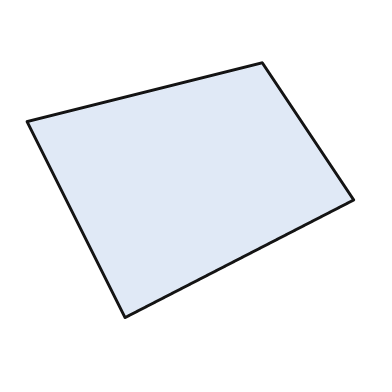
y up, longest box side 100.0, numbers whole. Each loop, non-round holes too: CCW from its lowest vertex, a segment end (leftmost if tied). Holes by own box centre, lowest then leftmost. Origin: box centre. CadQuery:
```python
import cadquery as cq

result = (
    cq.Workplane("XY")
    .moveTo(-20.0, -39.0)
    .lineTo(50.0, -3.0)
    .lineTo(22.0, 39.0)
    .lineTo(-50.0, 21.0)
    .close()
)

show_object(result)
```